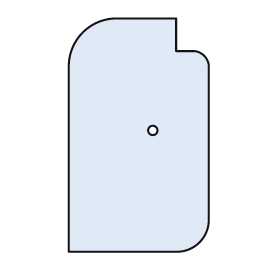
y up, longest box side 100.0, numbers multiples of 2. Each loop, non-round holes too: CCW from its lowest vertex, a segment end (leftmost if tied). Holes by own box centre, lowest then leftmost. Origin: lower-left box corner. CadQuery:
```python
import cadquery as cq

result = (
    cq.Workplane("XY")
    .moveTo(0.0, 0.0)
    .lineTo(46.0, 0.0)
    .threePointArc((56.0, 4.0), (60.0, 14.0))
    .lineTo(60.0, 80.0)
    .threePointArc((58.0, 84.0), (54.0, 86.0))
    .lineTo(46.0, 86.0)
    .lineTo(46.0, 100.0)
    .lineTo(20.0, 100.0)
    .threePointArc((6.0, 94.0), (0.0, 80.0))
    .close()
    .moveTo(36.0, 52.0)
    .circle(2.0)
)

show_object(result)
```